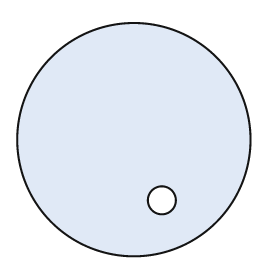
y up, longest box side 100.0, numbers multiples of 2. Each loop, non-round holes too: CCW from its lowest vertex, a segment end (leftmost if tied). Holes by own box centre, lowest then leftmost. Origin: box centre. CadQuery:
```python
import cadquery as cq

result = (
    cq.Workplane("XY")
    .moveTo(0.0, 0.0)
    .circle(50.0)
    .moveTo(12.0, -26.0)
    .circle(6.0)
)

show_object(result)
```